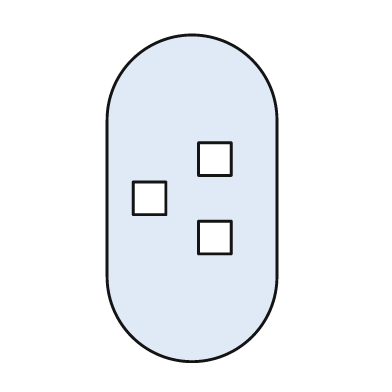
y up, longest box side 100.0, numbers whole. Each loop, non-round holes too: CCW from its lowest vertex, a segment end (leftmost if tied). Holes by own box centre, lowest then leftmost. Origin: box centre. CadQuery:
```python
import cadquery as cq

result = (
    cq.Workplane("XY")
    .moveTo(-26.0, -24.0)
    .threePointArc((0.0, -50.0), (26.0, -24.0))
    .lineTo(26.0, 24.0)
    .threePointArc((0.0, 50.0), (-26.0, 24.0))
    .close()
    .moveTo(2.0, -17.0)
    .lineTo(12.0, -17.0)
    .lineTo(12.0, -7.0)
    .lineTo(2.0, -7.0)
    .close()
    .moveTo(-18.0, -5.0)
    .lineTo(-8.0, -5.0)
    .lineTo(-8.0, 5.0)
    .lineTo(-18.0, 5.0)
    .close()
    .moveTo(2.0, 7.0)
    .lineTo(12.0, 7.0)
    .lineTo(12.0, 17.0)
    .lineTo(2.0, 17.0)
    .close()
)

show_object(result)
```